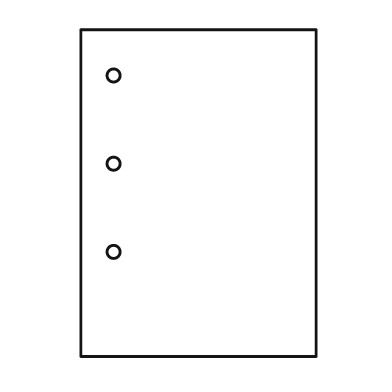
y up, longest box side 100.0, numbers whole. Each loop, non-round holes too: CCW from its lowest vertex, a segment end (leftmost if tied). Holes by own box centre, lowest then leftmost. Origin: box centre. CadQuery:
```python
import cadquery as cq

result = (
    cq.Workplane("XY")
    .moveTo(-36.0, -50.0)
    .lineTo(36.0, -50.0)
    .lineTo(36.0, 50.0)
    .lineTo(-36.0, 50.0)
    .close()
    .moveTo(-26.0, -18.0)
    .circle(2.0)
    .moveTo(-26.0, 9.0)
    .circle(2.0)
    .moveTo(-26.0, 36.0)
    .circle(2.0)
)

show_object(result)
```